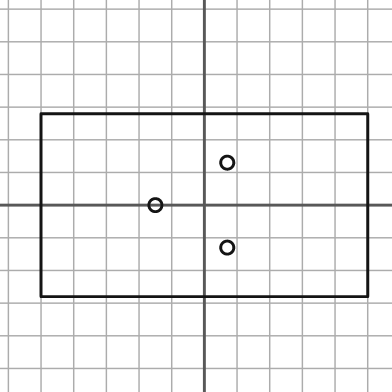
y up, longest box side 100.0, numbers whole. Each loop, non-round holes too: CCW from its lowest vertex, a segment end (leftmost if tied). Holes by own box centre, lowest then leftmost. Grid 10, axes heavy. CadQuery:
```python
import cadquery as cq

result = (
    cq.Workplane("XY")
    .moveTo(-50.0, -28.0)
    .lineTo(50.0, -28.0)
    .lineTo(50.0, 28.0)
    .lineTo(-50.0, 28.0)
    .close()
    .moveTo(7.0, -13.0)
    .circle(2.0)
    .moveTo(-15.0, 0.0)
    .circle(2.0)
    .moveTo(7.0, 13.0)
    .circle(2.0)
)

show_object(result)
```